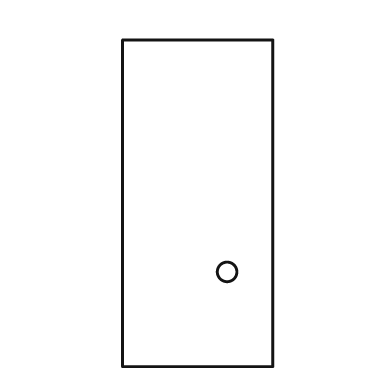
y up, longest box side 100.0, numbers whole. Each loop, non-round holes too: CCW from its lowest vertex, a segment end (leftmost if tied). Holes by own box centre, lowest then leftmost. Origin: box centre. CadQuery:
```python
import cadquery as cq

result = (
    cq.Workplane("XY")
    .moveTo(-23.0, -50.0)
    .lineTo(23.0, -50.0)
    .lineTo(23.0, 50.0)
    .lineTo(-23.0, 50.0)
    .close()
    .moveTo(9.0, -21.0)
    .circle(3.0)
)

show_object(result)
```